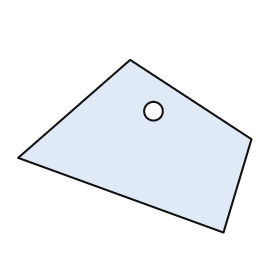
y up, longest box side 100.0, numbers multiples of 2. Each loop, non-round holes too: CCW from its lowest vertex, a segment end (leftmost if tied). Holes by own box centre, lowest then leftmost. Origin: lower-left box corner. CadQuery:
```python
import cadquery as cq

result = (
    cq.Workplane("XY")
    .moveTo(88.0, 0.0)
    .lineTo(100.0, 40.0)
    .lineTo(48.0, 74.0)
    .lineTo(0.0, 32.0)
    .close()
    .moveTo(58.0, 52.0)
    .circle(4.0)
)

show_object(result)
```